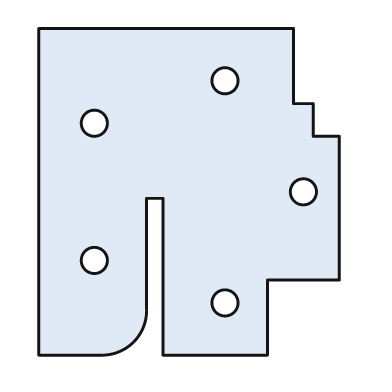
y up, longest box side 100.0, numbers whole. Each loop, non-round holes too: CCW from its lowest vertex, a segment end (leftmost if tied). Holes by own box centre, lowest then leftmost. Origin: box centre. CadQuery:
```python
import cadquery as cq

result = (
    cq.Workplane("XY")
    .moveTo(-46.0, -50.0)
    .lineTo(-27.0, -50.0)
    .threePointArc((-17.0, -46.0), (-13.0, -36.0))
    .lineTo(-13.0, -2.0)
    .lineTo(-8.0, -2.0)
    .lineTo(-8.0, -50.0)
    .lineTo(24.0, -50.0)
    .lineTo(24.0, -27.0)
    .lineTo(46.0, -27.0)
    .lineTo(46.0, 17.0)
    .lineTo(38.0, 17.0)
    .lineTo(38.0, 27.0)
    .lineTo(32.0, 27.0)
    .lineTo(32.0, 50.0)
    .lineTo(-46.0, 50.0)
    .close()
    .moveTo(11.0, -34.0)
    .circle(4.0)
    .moveTo(-29.0, -21.0)
    .circle(4.0)
    .moveTo(35.0, 0.0)
    .circle(4.0)
    .moveTo(-29.0, 21.0)
    .circle(4.0)
    .moveTo(11.0, 34.0)
    .circle(4.0)
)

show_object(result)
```